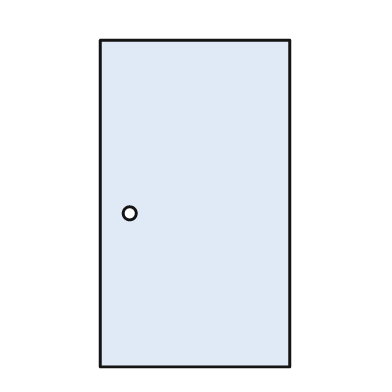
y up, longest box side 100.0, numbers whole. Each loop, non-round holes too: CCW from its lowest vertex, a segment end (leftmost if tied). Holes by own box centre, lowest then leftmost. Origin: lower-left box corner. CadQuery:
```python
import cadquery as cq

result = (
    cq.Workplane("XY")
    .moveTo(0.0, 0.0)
    .lineTo(58.0, 0.0)
    .lineTo(58.0, 100.0)
    .lineTo(0.0, 100.0)
    .close()
    .moveTo(9.0, 47.0)
    .circle(2.0)
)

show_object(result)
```